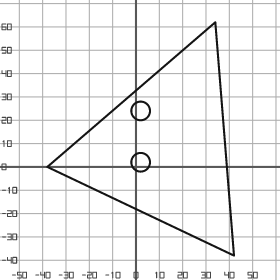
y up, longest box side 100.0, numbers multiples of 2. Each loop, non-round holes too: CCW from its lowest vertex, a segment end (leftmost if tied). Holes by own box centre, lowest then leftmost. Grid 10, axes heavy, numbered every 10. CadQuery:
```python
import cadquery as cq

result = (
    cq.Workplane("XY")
    .moveTo(42.0, -38.0)
    .lineTo(34.0, 62.0)
    .lineTo(-38.0, 0.0)
    .close()
    .moveTo(2.0, 2.0)
    .circle(4.0)
    .moveTo(2.0, 24.0)
    .circle(4.0)
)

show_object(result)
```